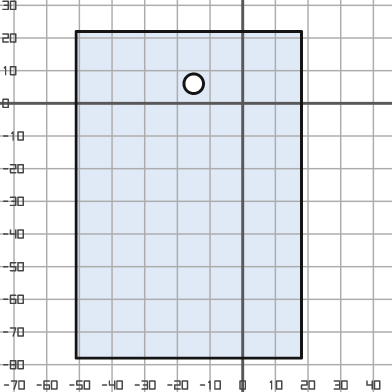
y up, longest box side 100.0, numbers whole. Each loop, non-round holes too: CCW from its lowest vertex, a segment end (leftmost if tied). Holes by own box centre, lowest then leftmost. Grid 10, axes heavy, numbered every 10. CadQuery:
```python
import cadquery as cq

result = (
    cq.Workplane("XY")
    .moveTo(-51.0, -78.0)
    .lineTo(18.0, -78.0)
    .lineTo(18.0, 22.0)
    .lineTo(-51.0, 22.0)
    .close()
    .moveTo(-15.0, 6.0)
    .circle(3.0)
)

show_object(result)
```